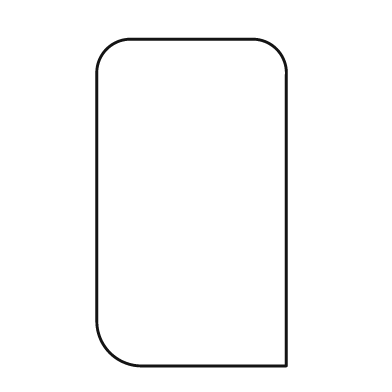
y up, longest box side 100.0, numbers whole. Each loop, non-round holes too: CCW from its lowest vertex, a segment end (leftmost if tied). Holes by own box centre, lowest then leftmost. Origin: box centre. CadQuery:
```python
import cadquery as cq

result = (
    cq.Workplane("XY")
    .moveTo(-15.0, -50.0)
    .lineTo(29.0, -50.0)
    .lineTo(29.0, 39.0)
    .threePointArc((26.0, 47.0), (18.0, 50.0))
    .lineTo(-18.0, 50.0)
    .threePointArc((-26.0, 47.0), (-29.0, 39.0))
    .lineTo(-29.0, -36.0)
    .threePointArc((-25.0, -46.0), (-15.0, -50.0))
    .close()
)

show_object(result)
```